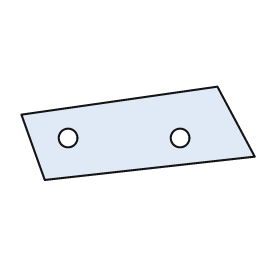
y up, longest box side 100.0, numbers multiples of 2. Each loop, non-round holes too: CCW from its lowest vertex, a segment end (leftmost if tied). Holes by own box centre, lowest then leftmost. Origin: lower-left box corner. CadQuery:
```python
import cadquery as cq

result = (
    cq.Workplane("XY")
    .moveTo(10.0, 0.0)
    .lineTo(100.0, 10.0)
    .lineTo(84.0, 40.0)
    .lineTo(0.0, 28.0)
    .close()
    .moveTo(20.0, 18.0)
    .circle(4.0)
    .moveTo(68.0, 18.0)
    .circle(4.0)
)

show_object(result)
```